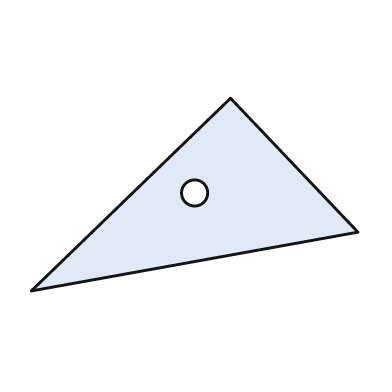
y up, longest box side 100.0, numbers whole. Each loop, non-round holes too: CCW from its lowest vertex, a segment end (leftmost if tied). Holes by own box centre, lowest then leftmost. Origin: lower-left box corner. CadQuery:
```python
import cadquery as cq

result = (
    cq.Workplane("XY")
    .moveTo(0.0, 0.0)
    .lineTo(100.0, 18.0)
    .lineTo(61.0, 59.0)
    .close()
    .moveTo(50.0, 30.0)
    .circle(4.0)
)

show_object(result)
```